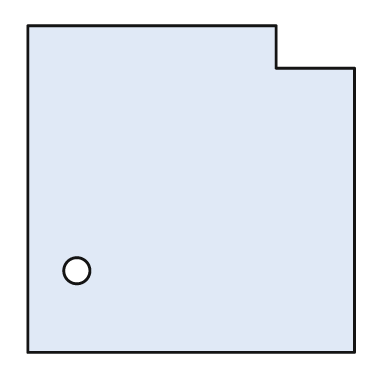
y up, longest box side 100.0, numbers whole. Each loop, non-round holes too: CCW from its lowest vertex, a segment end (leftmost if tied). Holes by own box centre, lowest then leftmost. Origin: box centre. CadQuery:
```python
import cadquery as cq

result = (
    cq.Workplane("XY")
    .moveTo(-50.0, -50.0)
    .lineTo(50.0, -50.0)
    .lineTo(50.0, 37.0)
    .lineTo(26.0, 37.0)
    .lineTo(26.0, 50.0)
    .lineTo(-50.0, 50.0)
    .close()
    .moveTo(-35.0, -25.0)
    .circle(4.0)
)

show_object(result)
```